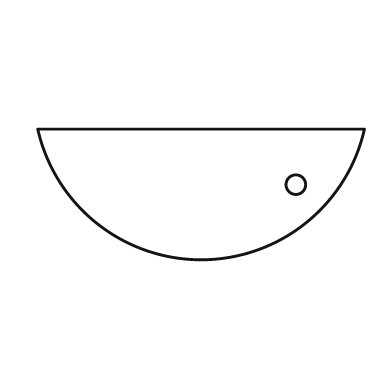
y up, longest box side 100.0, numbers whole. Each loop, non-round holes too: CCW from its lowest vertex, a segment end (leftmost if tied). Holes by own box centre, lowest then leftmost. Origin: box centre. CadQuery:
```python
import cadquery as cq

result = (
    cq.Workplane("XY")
    .moveTo(-50.0, 20.0)
    .threePointArc((0.0, -20.0), (50.0, 20.0))
    .close()
    .moveTo(29.0, 3.0)
    .circle(3.0)
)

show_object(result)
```